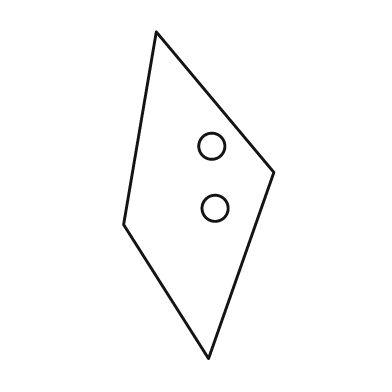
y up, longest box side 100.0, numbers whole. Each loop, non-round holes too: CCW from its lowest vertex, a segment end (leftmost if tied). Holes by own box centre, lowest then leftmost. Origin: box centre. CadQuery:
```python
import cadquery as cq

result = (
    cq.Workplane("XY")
    .moveTo(3.0, -50.0)
    .lineTo(23.0, 7.0)
    .lineTo(-13.0, 50.0)
    .lineTo(-23.0, -9.0)
    .close()
    .moveTo(5.0, -4.0)
    .circle(4.0)
    .moveTo(4.0, 15.0)
    .circle(4.0)
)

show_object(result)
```